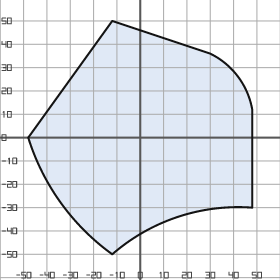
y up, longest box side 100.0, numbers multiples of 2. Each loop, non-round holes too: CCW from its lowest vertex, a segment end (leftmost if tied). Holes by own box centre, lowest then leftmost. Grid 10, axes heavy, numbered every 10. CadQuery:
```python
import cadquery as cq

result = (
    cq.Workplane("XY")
    .moveTo(-12.0, -50.0)
    .threePointArc((16.0, -34.0), (48.0, -30.0))
    .lineTo(48.0, 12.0)
    .threePointArc((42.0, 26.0), (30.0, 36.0))
    .lineTo(-12.0, 50.0)
    .lineTo(-48.0, 0.0)
    .threePointArc((-34.0, -28.0), (-12.0, -50.0))
    .close()
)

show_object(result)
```